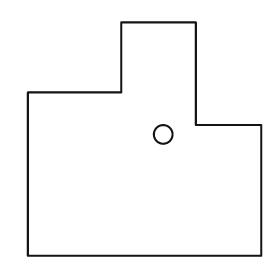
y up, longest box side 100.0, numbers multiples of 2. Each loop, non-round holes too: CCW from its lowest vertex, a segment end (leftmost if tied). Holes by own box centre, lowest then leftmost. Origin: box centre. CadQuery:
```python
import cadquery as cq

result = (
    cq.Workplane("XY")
    .moveTo(-50.0, -50.0)
    .lineTo(50.0, -50.0)
    .lineTo(50.0, 6.0)
    .lineTo(22.0, 6.0)
    .lineTo(22.0, 50.0)
    .lineTo(-10.0, 50.0)
    .lineTo(-10.0, 20.0)
    .lineTo(-50.0, 20.0)
    .close()
    .moveTo(8.0, 2.0)
    .circle(4.0)
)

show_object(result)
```